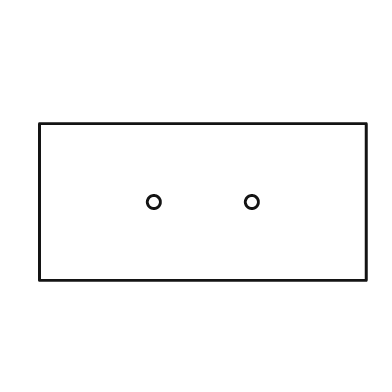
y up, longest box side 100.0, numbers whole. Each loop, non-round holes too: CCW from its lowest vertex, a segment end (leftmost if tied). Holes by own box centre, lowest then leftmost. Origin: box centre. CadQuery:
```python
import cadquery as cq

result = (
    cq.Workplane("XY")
    .moveTo(-50.0, -24.0)
    .lineTo(50.0, -24.0)
    .lineTo(50.0, 24.0)
    .lineTo(-50.0, 24.0)
    .close()
    .moveTo(-15.0, 0.0)
    .circle(2.0)
    .moveTo(15.0, 0.0)
    .circle(2.0)
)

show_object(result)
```